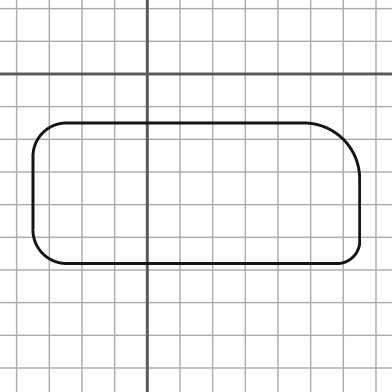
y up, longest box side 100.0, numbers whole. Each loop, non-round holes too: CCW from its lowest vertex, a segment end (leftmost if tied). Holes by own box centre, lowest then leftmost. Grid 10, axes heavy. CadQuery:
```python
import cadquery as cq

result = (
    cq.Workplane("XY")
    .moveTo(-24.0, -58.0)
    .lineTo(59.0, -58.0)
    .threePointArc((63.0, -56.0), (65.0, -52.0))
    .lineTo(65.0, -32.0)
    .threePointArc((60.0, -20.0), (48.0, -15.0))
    .lineTo(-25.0, -15.0)
    .threePointArc((-32.0, -18.0), (-35.0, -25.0))
    .lineTo(-35.0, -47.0)
    .threePointArc((-32.0, -55.0), (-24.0, -58.0))
    .close()
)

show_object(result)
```